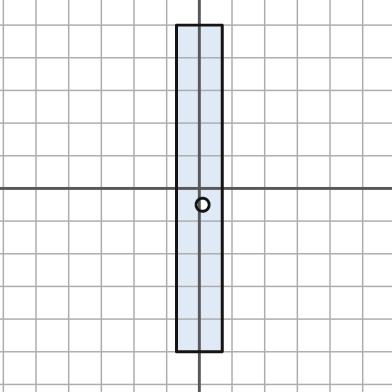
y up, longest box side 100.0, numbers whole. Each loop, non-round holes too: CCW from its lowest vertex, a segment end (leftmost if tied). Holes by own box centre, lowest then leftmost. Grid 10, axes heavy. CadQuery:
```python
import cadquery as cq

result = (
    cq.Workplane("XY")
    .moveTo(-7.0, -50.0)
    .lineTo(7.0, -50.0)
    .lineTo(7.0, 50.0)
    .lineTo(-7.0, 50.0)
    .close()
    .moveTo(1.0, -5.0)
    .circle(2.0)
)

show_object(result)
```